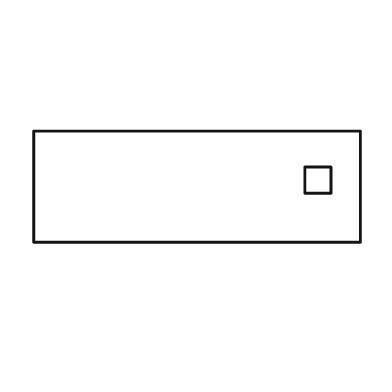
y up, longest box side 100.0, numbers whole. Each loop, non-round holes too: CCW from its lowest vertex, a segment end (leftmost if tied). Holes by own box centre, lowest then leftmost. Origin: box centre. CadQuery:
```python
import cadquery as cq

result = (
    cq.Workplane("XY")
    .moveTo(-50.0, -17.0)
    .lineTo(50.0, -17.0)
    .lineTo(50.0, 17.0)
    .lineTo(-50.0, 17.0)
    .close()
    .moveTo(33.0, -2.0)
    .lineTo(41.0, -2.0)
    .lineTo(41.0, 6.0)
    .lineTo(33.0, 6.0)
    .close()
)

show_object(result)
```